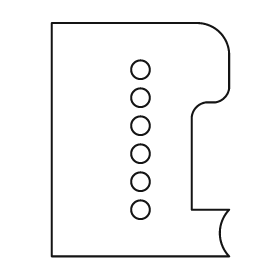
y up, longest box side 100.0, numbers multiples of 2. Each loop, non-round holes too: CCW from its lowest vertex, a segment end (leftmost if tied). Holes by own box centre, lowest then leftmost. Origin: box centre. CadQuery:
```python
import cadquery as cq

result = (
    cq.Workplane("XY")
    .moveTo(-38.0, -50.0)
    .lineTo(38.0, -50.0)
    .threePointArc((34.0, -40.0), (38.0, -30.0))
    .lineTo(22.0, -30.0)
    .lineTo(22.0, 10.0)
    .threePointArc((24.0, 14.0), (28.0, 16.0))
    .lineTo(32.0, 16.0)
    .threePointArc((36.0, 18.0), (38.0, 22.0))
    .lineTo(38.0, 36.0)
    .threePointArc((34.0, 46.0), (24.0, 50.0))
    .lineTo(-38.0, 50.0)
    .close()
    .moveTo(0.0, -30.0)
    .circle(4.0)
    .moveTo(0.0, -18.0)
    .circle(4.0)
    .moveTo(0.0, -6.0)
    .circle(4.0)
    .moveTo(0.0, 6.0)
    .circle(4.0)
    .moveTo(0.0, 18.0)
    .circle(4.0)
    .moveTo(0.0, 30.0)
    .circle(4.0)
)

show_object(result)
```